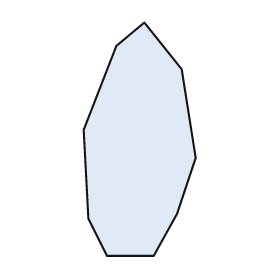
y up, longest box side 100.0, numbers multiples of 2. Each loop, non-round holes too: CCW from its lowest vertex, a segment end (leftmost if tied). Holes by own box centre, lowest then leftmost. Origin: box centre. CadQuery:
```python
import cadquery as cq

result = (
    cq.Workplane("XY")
    .moveTo(-14.0, -50.0)
    .lineTo(6.0, -50.0)
    .lineTo(16.0, -32.0)
    .lineTo(24.0, -8.0)
    .lineTo(18.0, 30.0)
    .lineTo(2.0, 50.0)
    .lineTo(-10.0, 40.0)
    .lineTo(-24.0, 4.0)
    .lineTo(-22.0, -34.0)
    .close()
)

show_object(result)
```